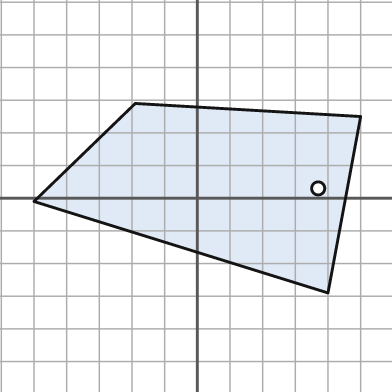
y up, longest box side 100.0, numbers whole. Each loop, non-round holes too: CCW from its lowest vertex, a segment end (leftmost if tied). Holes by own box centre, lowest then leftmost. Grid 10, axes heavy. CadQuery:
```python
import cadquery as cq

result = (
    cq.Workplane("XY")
    .moveTo(40.0, -29.0)
    .lineTo(50.0, 25.0)
    .lineTo(-19.0, 29.0)
    .lineTo(-50.0, -1.0)
    .close()
    .moveTo(37.0, 3.0)
    .circle(2.0)
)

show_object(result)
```